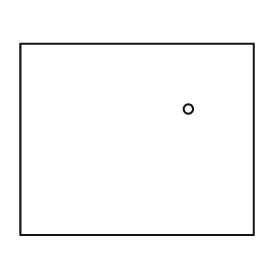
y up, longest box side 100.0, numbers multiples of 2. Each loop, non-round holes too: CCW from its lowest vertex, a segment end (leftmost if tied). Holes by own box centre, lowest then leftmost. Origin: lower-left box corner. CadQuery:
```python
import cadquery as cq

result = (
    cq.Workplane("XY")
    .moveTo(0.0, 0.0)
    .lineTo(100.0, 0.0)
    .lineTo(100.0, 82.0)
    .lineTo(0.0, 82.0)
    .close()
    .moveTo(72.0, 54.0)
    .circle(2.0)
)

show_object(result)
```